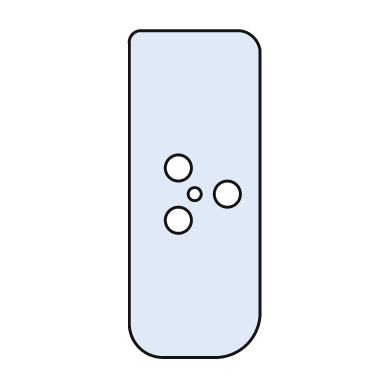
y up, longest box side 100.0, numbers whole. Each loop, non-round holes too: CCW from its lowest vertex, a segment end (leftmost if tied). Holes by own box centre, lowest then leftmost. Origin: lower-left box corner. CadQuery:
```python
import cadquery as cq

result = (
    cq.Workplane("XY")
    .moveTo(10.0, 0.0)
    .lineTo(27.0, 0.0)
    .threePointArc((36.0, 4.0), (40.0, 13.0))
    .lineTo(40.0, 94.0)
    .threePointArc((38.0, 98.0), (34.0, 100.0))
    .lineTo(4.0, 100.0)
    .threePointArc((1.0, 99.0), (0.0, 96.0))
    .lineTo(0.0, 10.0)
    .threePointArc((3.0, 3.0), (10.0, 0.0))
    .close()
    .moveTo(15.0, 42.0)
    .circle(4.0)
    .moveTo(20.0, 50.0)
    .circle(2.0)
    .moveTo(30.0, 50.0)
    .circle(4.0)
    .moveTo(15.0, 58.0)
    .circle(4.0)
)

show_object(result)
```